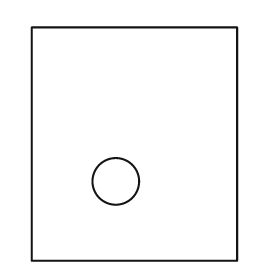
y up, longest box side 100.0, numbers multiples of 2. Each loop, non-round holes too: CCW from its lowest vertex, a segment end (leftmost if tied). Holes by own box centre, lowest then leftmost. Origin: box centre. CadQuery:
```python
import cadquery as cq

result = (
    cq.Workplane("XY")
    .moveTo(-44.0, -50.0)
    .lineTo(44.0, -50.0)
    .lineTo(44.0, 50.0)
    .lineTo(-44.0, 50.0)
    .close()
    .moveTo(-8.0, -16.0)
    .circle(10.0)
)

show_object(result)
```